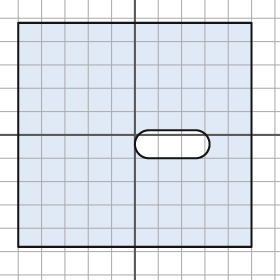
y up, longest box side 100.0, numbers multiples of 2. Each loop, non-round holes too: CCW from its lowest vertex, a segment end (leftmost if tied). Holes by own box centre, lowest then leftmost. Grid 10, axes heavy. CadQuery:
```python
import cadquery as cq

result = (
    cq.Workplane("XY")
    .moveTo(-50.0, -48.0)
    .lineTo(50.0, -48.0)
    .lineTo(50.0, 48.0)
    .lineTo(-50.0, 48.0)
    .close()
    .moveTo(6.0, -10.0)
    .lineTo(26.0, -10.0)
    .threePointArc((32.0, -4.0), (26.0, 2.0))
    .lineTo(6.0, 2.0)
    .threePointArc((0.0, -4.0), (6.0, -10.0))
    .close()
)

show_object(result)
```